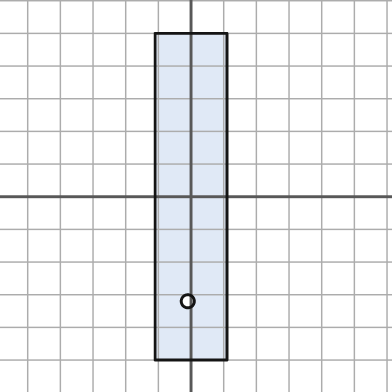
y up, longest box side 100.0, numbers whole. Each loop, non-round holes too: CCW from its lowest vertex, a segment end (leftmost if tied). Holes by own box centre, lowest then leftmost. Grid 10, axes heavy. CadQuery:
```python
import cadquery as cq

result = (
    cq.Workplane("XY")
    .moveTo(-11.0, -50.0)
    .lineTo(11.0, -50.0)
    .lineTo(11.0, 50.0)
    .lineTo(-11.0, 50.0)
    .close()
    .moveTo(-1.0, -32.0)
    .circle(2.0)
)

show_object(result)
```